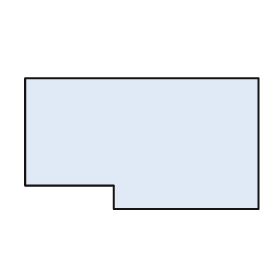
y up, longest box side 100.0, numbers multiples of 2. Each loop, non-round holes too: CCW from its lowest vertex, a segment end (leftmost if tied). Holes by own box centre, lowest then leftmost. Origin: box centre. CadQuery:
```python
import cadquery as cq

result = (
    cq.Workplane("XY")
    .moveTo(-12.0, -28.0)
    .lineTo(50.0, -28.0)
    .lineTo(50.0, 28.0)
    .lineTo(-50.0, 28.0)
    .lineTo(-50.0, -18.0)
    .lineTo(-12.0, -18.0)
    .close()
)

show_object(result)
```